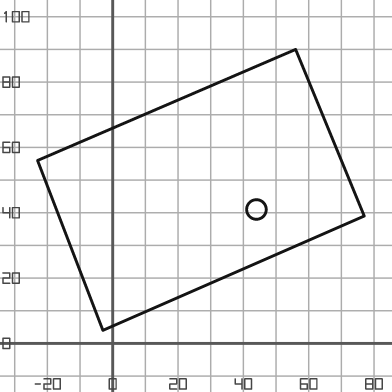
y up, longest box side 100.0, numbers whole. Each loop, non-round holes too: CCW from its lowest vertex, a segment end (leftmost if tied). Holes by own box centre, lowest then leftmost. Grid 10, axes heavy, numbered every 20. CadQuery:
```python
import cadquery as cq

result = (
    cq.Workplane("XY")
    .moveTo(-3.0, 4.0)
    .lineTo(77.0, 39.0)
    .lineTo(56.0, 90.0)
    .lineTo(-23.0, 56.0)
    .close()
    .moveTo(44.0, 41.0)
    .circle(3.0)
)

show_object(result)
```